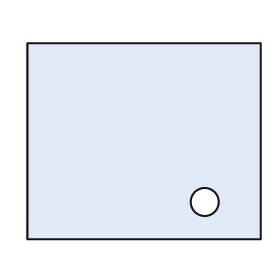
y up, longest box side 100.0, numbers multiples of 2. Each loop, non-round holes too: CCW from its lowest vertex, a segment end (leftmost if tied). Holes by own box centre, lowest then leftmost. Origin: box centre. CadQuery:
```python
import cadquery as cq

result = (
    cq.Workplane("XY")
    .moveTo(-50.0, -42.0)
    .lineTo(50.0, -42.0)
    .lineTo(50.0, 42.0)
    .lineTo(-50.0, 42.0)
    .close()
    .moveTo(26.0, -26.0)
    .circle(6.0)
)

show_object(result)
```